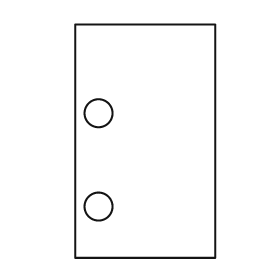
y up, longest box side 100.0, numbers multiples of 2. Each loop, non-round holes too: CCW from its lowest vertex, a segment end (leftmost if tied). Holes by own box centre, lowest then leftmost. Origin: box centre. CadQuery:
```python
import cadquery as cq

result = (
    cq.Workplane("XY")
    .moveTo(-30.0, -50.0)
    .lineTo(30.0, -50.0)
    .lineTo(30.0, 50.0)
    .lineTo(-30.0, 50.0)
    .close()
    .moveTo(-20.0, -28.0)
    .circle(6.0)
    .moveTo(-20.0, 12.0)
    .circle(6.0)
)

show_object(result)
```